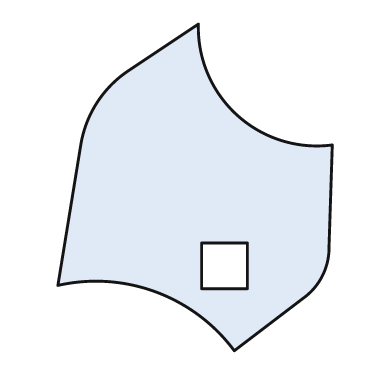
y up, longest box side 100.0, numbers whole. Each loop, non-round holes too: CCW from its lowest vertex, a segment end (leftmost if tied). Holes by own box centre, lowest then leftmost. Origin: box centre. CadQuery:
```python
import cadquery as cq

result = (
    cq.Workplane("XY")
    .moveTo(12.0, -50.0)
    .lineTo(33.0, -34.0)
    .threePointArc((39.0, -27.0), (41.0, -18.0))
    .lineTo(42.0, 13.0)
    .threePointArc((13.0, 22.0), (1.0, 50.0))
    .lineTo(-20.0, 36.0)
    .threePointArc((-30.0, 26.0), (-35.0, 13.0))
    .lineTo(-42.0, -30.0)
    .threePointArc((-12.0, -32.0), (12.0, -50.0))
    .close()
    .moveTo(2.0, -31.0)
    .lineTo(16.0, -31.0)
    .lineTo(16.0, -17.0)
    .lineTo(2.0, -17.0)
    .close()
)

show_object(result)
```